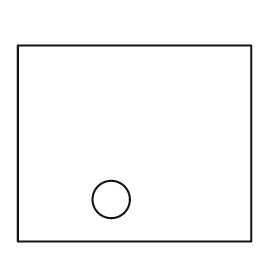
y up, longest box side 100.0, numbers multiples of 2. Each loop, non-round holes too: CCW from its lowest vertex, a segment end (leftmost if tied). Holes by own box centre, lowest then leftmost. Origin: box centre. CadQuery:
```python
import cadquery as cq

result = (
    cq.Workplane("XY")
    .moveTo(-50.0, -42.0)
    .lineTo(50.0, -42.0)
    .lineTo(50.0, 42.0)
    .lineTo(-50.0, 42.0)
    .close()
    .moveTo(-10.0, -24.0)
    .circle(8.0)
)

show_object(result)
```